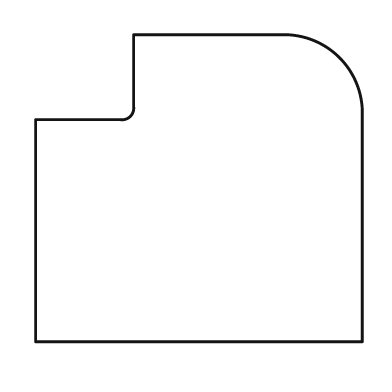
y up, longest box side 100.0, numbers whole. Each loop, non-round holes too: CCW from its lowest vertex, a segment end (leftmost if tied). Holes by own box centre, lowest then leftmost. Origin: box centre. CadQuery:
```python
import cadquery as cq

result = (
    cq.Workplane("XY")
    .moveTo(-50.0, -47.0)
    .lineTo(50.0, -47.0)
    .lineTo(50.0, 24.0)
    .threePointArc((43.0, 40.0), (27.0, 47.0))
    .lineTo(-20.0, 47.0)
    .lineTo(-20.0, 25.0)
    .threePointArc((-21.0, 22.0), (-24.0, 21.0))
    .lineTo(-50.0, 21.0)
    .close()
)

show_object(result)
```